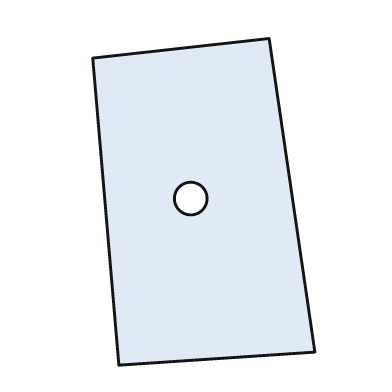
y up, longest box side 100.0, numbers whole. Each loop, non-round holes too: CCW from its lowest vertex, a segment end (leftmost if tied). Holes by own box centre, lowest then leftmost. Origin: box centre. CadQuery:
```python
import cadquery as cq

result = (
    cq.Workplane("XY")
    .moveTo(-26.0, -50.0)
    .lineTo(34.0, -46.0)
    .lineTo(20.0, 50.0)
    .lineTo(-34.0, 44.0)
    .close()
    .moveTo(-4.0, 1.0)
    .circle(5.0)
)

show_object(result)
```